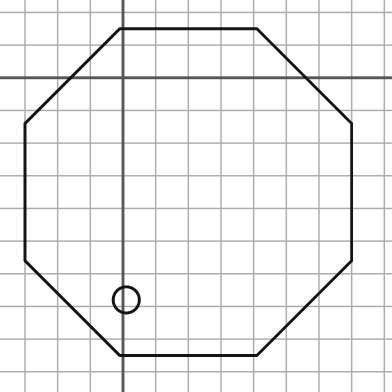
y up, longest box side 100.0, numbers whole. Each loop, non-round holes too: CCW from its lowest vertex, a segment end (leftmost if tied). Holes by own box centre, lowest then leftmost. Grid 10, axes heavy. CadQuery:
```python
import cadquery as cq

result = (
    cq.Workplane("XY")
    .moveTo(-1.0, -85.0)
    .lineTo(41.0, -85.0)
    .lineTo(70.0, -56.0)
    .lineTo(70.0, -14.0)
    .lineTo(41.0, 15.0)
    .lineTo(-1.0, 15.0)
    .lineTo(-30.0, -14.0)
    .lineTo(-30.0, -56.0)
    .close()
    .moveTo(1.0, -68.0)
    .circle(4.0)
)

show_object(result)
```